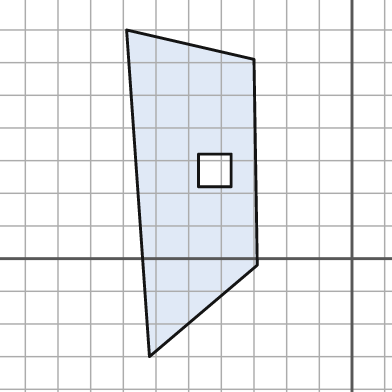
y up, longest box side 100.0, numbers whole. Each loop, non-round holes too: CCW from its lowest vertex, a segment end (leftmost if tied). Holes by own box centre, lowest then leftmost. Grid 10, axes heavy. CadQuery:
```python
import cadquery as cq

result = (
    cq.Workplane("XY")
    .moveTo(-62.0, -30.0)
    .lineTo(-29.0, -2.0)
    .lineTo(-30.0, 61.0)
    .lineTo(-69.0, 70.0)
    .close()
    .moveTo(-47.0, 22.0)
    .lineTo(-37.0, 22.0)
    .lineTo(-37.0, 32.0)
    .lineTo(-47.0, 32.0)
    .close()
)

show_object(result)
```